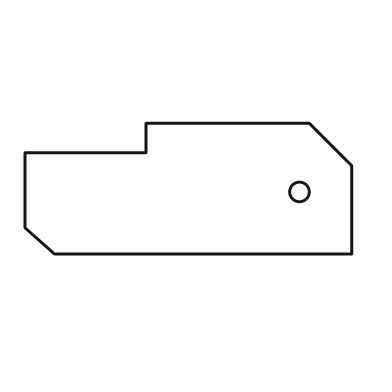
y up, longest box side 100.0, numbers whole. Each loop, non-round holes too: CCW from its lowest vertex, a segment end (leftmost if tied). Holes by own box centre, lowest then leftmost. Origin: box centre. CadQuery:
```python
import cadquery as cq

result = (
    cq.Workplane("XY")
    .moveTo(-41.0, -20.0)
    .lineTo(50.0, -20.0)
    .lineTo(50.0, 7.0)
    .lineTo(37.0, 20.0)
    .lineTo(-13.0, 20.0)
    .lineTo(-13.0, 11.0)
    .lineTo(-50.0, 11.0)
    .lineTo(-50.0, -12.0)
    .close()
    .moveTo(34.0, -1.0)
    .circle(3.0)
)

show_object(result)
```